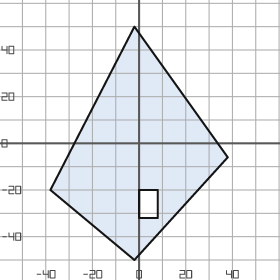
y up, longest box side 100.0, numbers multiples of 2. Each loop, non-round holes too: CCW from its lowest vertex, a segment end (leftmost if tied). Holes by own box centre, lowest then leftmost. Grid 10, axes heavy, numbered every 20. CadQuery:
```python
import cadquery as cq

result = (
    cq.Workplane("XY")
    .moveTo(-2.0, -50.0)
    .lineTo(38.0, -6.0)
    .lineTo(-2.0, 50.0)
    .lineTo(-38.0, -20.0)
    .close()
    .moveTo(0.0, -32.0)
    .lineTo(8.0, -32.0)
    .lineTo(8.0, -20.0)
    .lineTo(0.0, -20.0)
    .close()
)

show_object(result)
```